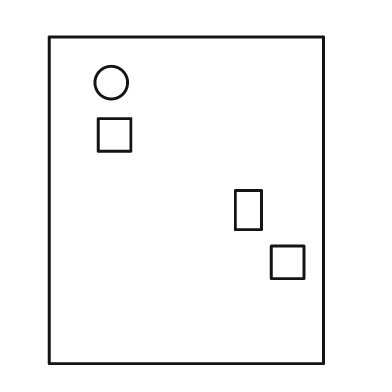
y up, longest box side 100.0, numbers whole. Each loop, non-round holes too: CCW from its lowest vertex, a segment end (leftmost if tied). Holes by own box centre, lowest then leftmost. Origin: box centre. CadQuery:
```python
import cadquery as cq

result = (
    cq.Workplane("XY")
    .moveTo(-42.0, -50.0)
    .lineTo(42.0, -50.0)
    .lineTo(42.0, 50.0)
    .lineTo(-42.0, 50.0)
    .close()
    .moveTo(26.0, -24.0)
    .lineTo(36.0, -24.0)
    .lineTo(36.0, -14.0)
    .lineTo(26.0, -14.0)
    .close()
    .moveTo(15.0, -9.0)
    .lineTo(23.0, -9.0)
    .lineTo(23.0, 3.0)
    .lineTo(15.0, 3.0)
    .close()
    .moveTo(-27.0, 15.0)
    .lineTo(-17.0, 15.0)
    .lineTo(-17.0, 25.0)
    .lineTo(-27.0, 25.0)
    .close()
    .moveTo(-23.0, 36.0)
    .circle(5.0)
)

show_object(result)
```